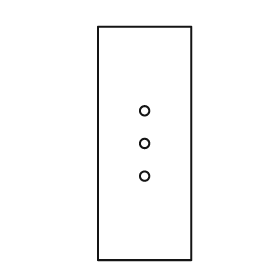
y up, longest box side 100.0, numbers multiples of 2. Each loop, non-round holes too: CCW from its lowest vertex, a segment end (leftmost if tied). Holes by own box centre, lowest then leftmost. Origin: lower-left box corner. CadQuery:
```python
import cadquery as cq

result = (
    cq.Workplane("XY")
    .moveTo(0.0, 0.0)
    .lineTo(40.0, 0.0)
    .lineTo(40.0, 100.0)
    .lineTo(0.0, 100.0)
    .close()
    .moveTo(20.0, 36.0)
    .circle(2.0)
    .moveTo(20.0, 50.0)
    .circle(2.0)
    .moveTo(20.0, 64.0)
    .circle(2.0)
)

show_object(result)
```